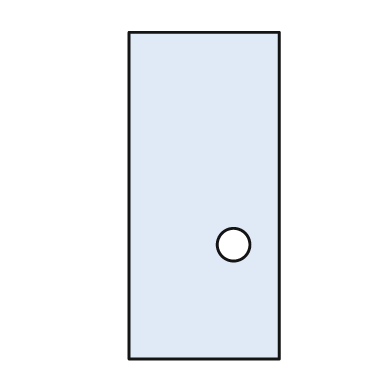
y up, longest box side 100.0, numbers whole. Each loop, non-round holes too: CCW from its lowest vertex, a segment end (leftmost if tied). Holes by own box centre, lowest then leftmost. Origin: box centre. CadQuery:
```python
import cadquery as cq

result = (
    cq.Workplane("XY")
    .moveTo(-23.0, -50.0)
    .lineTo(23.0, -50.0)
    .lineTo(23.0, 50.0)
    .lineTo(-23.0, 50.0)
    .close()
    .moveTo(9.0, -15.0)
    .circle(5.0)
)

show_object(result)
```